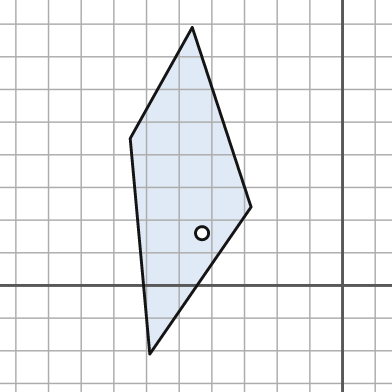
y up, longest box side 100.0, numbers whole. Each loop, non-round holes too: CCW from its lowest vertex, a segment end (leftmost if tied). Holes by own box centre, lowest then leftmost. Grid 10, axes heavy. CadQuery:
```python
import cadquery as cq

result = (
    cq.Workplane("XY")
    .moveTo(-59.0, -21.0)
    .lineTo(-28.0, 24.0)
    .lineTo(-46.0, 79.0)
    .lineTo(-65.0, 45.0)
    .close()
    .moveTo(-43.0, 16.0)
    .circle(2.0)
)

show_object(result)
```